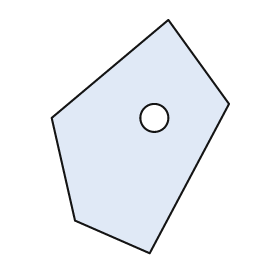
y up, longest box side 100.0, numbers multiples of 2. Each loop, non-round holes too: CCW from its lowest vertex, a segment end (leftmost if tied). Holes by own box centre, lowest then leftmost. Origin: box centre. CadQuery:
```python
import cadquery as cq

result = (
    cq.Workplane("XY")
    .moveTo(4.0, -50.0)
    .lineTo(38.0, 14.0)
    .lineTo(12.0, 50.0)
    .lineTo(-38.0, 8.0)
    .lineTo(-28.0, -36.0)
    .close()
    .moveTo(6.0, 8.0)
    .circle(6.0)
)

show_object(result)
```